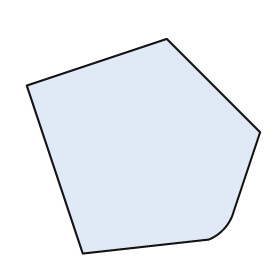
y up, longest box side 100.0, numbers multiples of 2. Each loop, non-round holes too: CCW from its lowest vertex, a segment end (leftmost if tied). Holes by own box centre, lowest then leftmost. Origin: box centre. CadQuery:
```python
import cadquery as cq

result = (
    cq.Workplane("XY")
    .moveTo(-26.0, -46.0)
    .lineTo(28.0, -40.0)
    .threePointArc((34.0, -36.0), (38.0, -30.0))
    .lineTo(50.0, 6.0)
    .lineTo(10.0, 46.0)
    .lineTo(-50.0, 26.0)
    .close()
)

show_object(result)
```